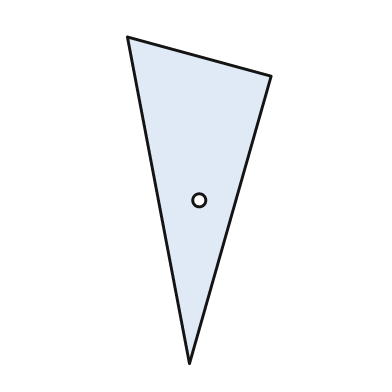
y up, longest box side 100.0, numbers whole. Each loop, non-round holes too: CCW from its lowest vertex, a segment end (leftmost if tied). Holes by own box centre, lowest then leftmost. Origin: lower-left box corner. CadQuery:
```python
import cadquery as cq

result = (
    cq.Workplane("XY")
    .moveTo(19.0, 0.0)
    .lineTo(44.0, 88.0)
    .lineTo(0.0, 100.0)
    .close()
    .moveTo(22.0, 50.0)
    .circle(2.0)
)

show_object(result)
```